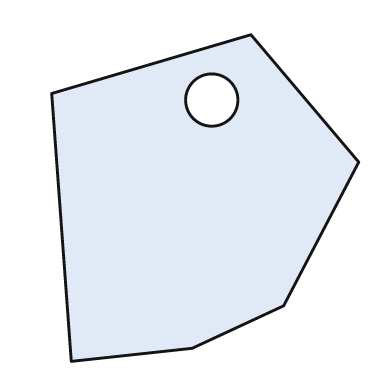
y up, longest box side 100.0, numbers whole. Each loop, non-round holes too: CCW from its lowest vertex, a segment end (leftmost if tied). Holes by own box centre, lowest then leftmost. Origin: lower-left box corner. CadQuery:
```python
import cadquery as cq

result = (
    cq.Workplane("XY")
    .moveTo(6.0, 0.0)
    .lineTo(43.0, 4.0)
    .lineTo(71.0, 17.0)
    .lineTo(94.0, 61.0)
    .lineTo(61.0, 100.0)
    .lineTo(0.0, 82.0)
    .close()
    .moveTo(49.0, 80.0)
    .circle(8.0)
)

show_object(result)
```